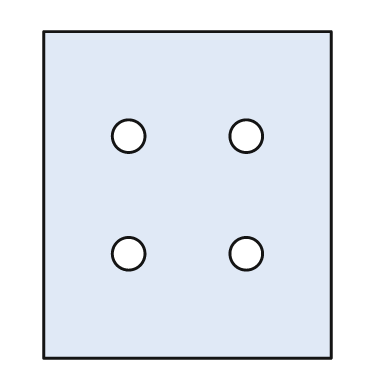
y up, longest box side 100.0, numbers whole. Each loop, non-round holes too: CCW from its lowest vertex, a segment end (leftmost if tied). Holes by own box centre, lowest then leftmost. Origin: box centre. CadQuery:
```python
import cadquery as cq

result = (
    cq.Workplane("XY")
    .moveTo(-44.0, -50.0)
    .lineTo(44.0, -50.0)
    .lineTo(44.0, 50.0)
    .lineTo(-44.0, 50.0)
    .close()
    .moveTo(-18.0, -18.0)
    .circle(5.0)
    .moveTo(18.0, -18.0)
    .circle(5.0)
    .moveTo(-18.0, 18.0)
    .circle(5.0)
    .moveTo(18.0, 18.0)
    .circle(5.0)
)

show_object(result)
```